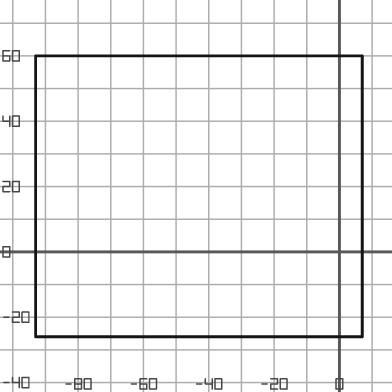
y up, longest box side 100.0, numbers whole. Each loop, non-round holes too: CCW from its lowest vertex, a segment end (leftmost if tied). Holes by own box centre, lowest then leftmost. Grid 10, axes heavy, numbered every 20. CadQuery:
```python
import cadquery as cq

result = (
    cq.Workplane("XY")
    .moveTo(-93.0, -26.0)
    .lineTo(7.0, -26.0)
    .lineTo(7.0, 60.0)
    .lineTo(-93.0, 60.0)
    .close()
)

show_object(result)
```